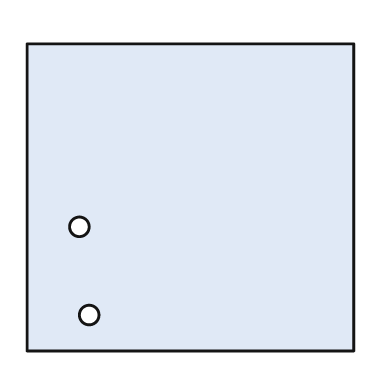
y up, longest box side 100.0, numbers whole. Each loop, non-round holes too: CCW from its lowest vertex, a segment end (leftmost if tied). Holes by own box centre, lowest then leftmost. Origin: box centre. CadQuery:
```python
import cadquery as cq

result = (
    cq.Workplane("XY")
    .moveTo(-50.0, -47.0)
    .lineTo(50.0, -47.0)
    .lineTo(50.0, 47.0)
    .lineTo(-50.0, 47.0)
    .close()
    .moveTo(-31.0, -36.0)
    .circle(3.0)
    .moveTo(-34.0, -9.0)
    .circle(3.0)
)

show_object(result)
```